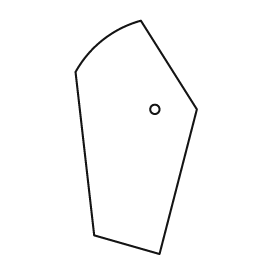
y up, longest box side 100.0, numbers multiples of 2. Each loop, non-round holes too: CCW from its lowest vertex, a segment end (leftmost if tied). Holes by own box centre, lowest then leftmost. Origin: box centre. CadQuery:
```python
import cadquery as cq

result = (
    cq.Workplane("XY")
    .moveTo(10.0, -50.0)
    .lineTo(26.0, 12.0)
    .lineTo(2.0, 50.0)
    .threePointArc((-14.0, 42.0), (-26.0, 28.0))
    .lineTo(-18.0, -42.0)
    .close()
    .moveTo(8.0, 12.0)
    .circle(2.0)
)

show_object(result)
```